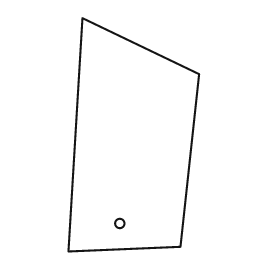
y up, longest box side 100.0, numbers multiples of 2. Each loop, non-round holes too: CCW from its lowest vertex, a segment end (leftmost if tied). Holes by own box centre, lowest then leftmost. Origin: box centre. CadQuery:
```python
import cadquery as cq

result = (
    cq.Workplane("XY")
    .moveTo(-28.0, -50.0)
    .lineTo(20.0, -48.0)
    .lineTo(28.0, 26.0)
    .lineTo(-22.0, 50.0)
    .close()
    .moveTo(-6.0, -38.0)
    .circle(2.0)
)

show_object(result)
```